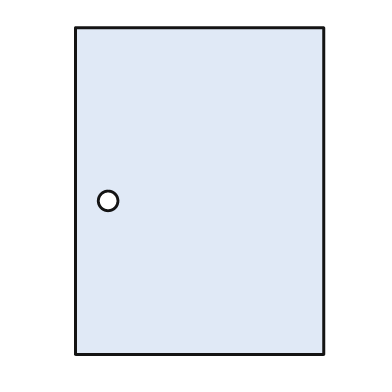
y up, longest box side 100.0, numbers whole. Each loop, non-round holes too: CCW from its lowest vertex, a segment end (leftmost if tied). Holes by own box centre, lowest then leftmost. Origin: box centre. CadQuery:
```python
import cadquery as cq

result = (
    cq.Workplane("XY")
    .moveTo(-38.0, -50.0)
    .lineTo(38.0, -50.0)
    .lineTo(38.0, 50.0)
    .lineTo(-38.0, 50.0)
    .close()
    .moveTo(-28.0, -3.0)
    .circle(3.0)
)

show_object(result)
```